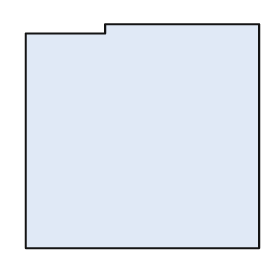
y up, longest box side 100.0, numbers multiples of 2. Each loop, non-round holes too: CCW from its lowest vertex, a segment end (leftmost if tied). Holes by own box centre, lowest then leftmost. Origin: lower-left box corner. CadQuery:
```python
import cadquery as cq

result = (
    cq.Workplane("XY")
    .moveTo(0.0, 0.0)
    .lineTo(100.0, 0.0)
    .lineTo(100.0, 96.0)
    .lineTo(34.0, 96.0)
    .lineTo(34.0, 92.0)
    .lineTo(0.0, 92.0)
    .close()
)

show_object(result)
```